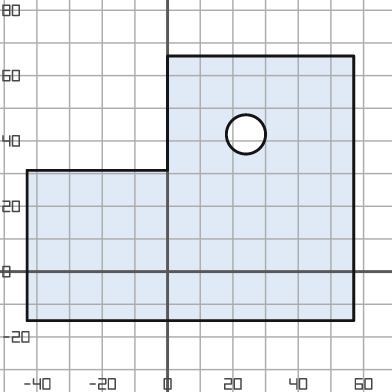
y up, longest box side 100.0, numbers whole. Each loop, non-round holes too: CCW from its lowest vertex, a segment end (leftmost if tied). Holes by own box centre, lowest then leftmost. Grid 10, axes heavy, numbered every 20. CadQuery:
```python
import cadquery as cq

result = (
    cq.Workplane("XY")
    .moveTo(-43.0, -15.0)
    .lineTo(57.0, -15.0)
    .lineTo(57.0, 66.0)
    .lineTo(0.0, 66.0)
    .lineTo(0.0, 31.0)
    .lineTo(-43.0, 31.0)
    .close()
    .moveTo(24.0, 42.0)
    .circle(6.0)
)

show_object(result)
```